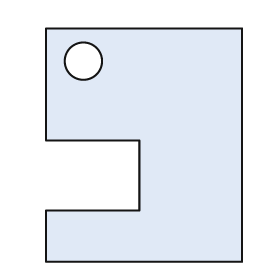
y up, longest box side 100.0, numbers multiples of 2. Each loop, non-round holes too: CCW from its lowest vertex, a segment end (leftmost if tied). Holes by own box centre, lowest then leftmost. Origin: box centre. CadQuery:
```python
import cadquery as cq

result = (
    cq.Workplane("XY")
    .moveTo(-42.0, -50.0)
    .lineTo(42.0, -50.0)
    .lineTo(42.0, 50.0)
    .lineTo(-42.0, 50.0)
    .lineTo(-42.0, 2.0)
    .lineTo(-2.0, 2.0)
    .lineTo(-2.0, -28.0)
    .lineTo(-42.0, -28.0)
    .close()
    .moveTo(-26.0, 36.0)
    .circle(8.0)
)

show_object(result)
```